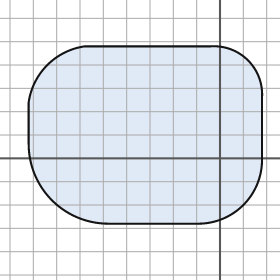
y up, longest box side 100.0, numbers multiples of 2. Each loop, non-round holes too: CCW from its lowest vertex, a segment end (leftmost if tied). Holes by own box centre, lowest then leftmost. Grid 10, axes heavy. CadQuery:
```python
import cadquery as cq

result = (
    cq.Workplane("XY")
    .moveTo(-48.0, -28.0)
    .lineTo(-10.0, -28.0)
    .threePointArc((10.0, -20.0), (18.0, 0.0))
    .lineTo(18.0, 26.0)
    .threePointArc((12.0, 42.0), (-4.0, 48.0))
    .lineTo(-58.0, 48.0)
    .threePointArc((-74.0, 40.0), (-82.0, 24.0))
    .lineTo(-82.0, 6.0)
    .threePointArc((-72.0, -18.0), (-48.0, -28.0))
    .close()
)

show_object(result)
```